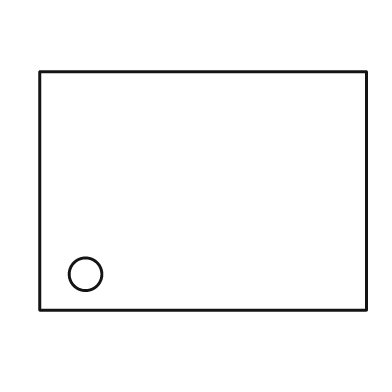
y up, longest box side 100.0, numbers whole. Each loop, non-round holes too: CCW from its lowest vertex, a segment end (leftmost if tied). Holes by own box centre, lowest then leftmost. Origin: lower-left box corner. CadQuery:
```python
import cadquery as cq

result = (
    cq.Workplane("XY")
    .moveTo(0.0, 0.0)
    .lineTo(100.0, 0.0)
    .lineTo(100.0, 73.0)
    .lineTo(0.0, 73.0)
    .close()
    .moveTo(14.0, 11.0)
    .circle(5.0)
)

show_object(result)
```